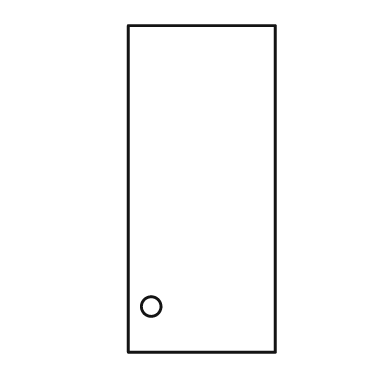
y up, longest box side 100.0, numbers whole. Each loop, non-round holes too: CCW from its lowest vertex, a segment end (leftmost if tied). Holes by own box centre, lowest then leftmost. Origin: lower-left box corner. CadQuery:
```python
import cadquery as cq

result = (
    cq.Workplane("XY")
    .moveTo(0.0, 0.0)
    .lineTo(45.0, 0.0)
    .lineTo(45.0, 100.0)
    .lineTo(0.0, 100.0)
    .close()
    .moveTo(7.0, 14.0)
    .circle(3.0)
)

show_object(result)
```